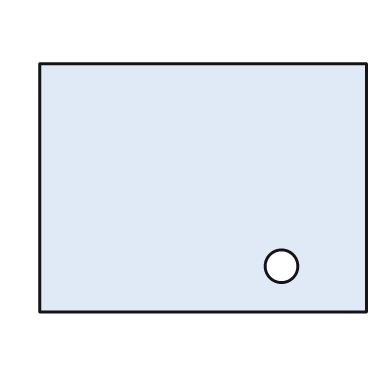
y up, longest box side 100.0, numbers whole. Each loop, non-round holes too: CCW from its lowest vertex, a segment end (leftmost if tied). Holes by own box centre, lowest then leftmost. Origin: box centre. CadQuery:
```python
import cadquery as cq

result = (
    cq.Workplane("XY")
    .moveTo(-50.0, -38.0)
    .lineTo(50.0, -38.0)
    .lineTo(50.0, 38.0)
    .lineTo(-50.0, 38.0)
    .close()
    .moveTo(24.0, -24.0)
    .circle(5.0)
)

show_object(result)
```